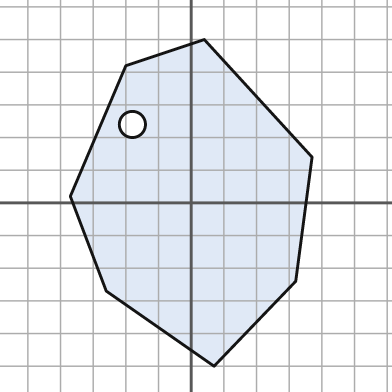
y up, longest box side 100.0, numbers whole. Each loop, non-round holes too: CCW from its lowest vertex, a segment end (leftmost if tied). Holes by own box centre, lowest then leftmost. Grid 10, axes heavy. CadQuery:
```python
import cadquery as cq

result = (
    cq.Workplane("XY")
    .moveTo(7.0, -50.0)
    .lineTo(32.0, -24.0)
    .lineTo(37.0, 14.0)
    .lineTo(4.0, 50.0)
    .lineTo(-20.0, 42.0)
    .lineTo(-37.0, 2.0)
    .lineTo(-26.0, -27.0)
    .close()
    .moveTo(-18.0, 24.0)
    .circle(4.0)
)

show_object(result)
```